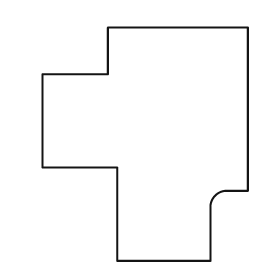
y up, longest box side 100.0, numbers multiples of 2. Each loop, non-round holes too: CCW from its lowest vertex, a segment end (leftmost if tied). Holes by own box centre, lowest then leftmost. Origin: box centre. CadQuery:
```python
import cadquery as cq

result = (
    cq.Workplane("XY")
    .moveTo(-12.0, -50.0)
    .lineTo(28.0, -50.0)
    .lineTo(28.0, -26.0)
    .threePointArc((30.0, -22.0), (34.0, -20.0))
    .lineTo(44.0, -20.0)
    .lineTo(44.0, 50.0)
    .lineTo(-16.0, 50.0)
    .lineTo(-16.0, 30.0)
    .lineTo(-44.0, 30.0)
    .lineTo(-44.0, -10.0)
    .lineTo(-12.0, -10.0)
    .close()
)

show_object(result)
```